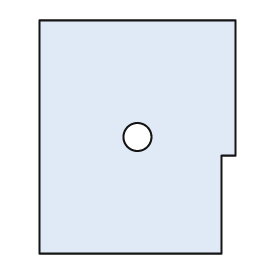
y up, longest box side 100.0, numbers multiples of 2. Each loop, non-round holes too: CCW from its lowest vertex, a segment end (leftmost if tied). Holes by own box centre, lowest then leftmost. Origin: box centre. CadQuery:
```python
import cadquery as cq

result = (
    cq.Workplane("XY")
    .moveTo(-42.0, -50.0)
    .lineTo(36.0, -50.0)
    .lineTo(36.0, -8.0)
    .lineTo(42.0, -8.0)
    .lineTo(42.0, 50.0)
    .lineTo(-42.0, 50.0)
    .close()
    .moveTo(0.0, 0.0)
    .circle(6.0)
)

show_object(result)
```